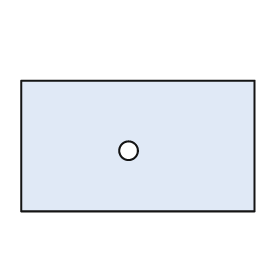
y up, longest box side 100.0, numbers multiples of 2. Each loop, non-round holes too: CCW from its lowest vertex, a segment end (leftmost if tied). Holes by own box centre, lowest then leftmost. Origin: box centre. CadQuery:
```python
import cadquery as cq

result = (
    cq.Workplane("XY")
    .moveTo(-50.0, -28.0)
    .lineTo(50.0, -28.0)
    .lineTo(50.0, 28.0)
    .lineTo(-50.0, 28.0)
    .close()
    .moveTo(-4.0, -2.0)
    .circle(4.0)
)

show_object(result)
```